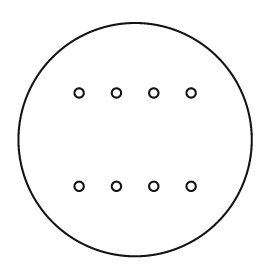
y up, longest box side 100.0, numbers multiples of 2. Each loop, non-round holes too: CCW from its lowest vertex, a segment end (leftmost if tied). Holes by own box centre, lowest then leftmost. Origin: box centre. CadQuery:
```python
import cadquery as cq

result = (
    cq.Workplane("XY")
    .moveTo(0.0, 0.0)
    .circle(50.0)
    .moveTo(-24.0, -20.0)
    .circle(2.0)
    .moveTo(-8.0, -20.0)
    .circle(2.0)
    .moveTo(8.0, -20.0)
    .circle(2.0)
    .moveTo(24.0, -20.0)
    .circle(2.0)
    .moveTo(-24.0, 20.0)
    .circle(2.0)
    .moveTo(-8.0, 20.0)
    .circle(2.0)
    .moveTo(8.0, 20.0)
    .circle(2.0)
    .moveTo(24.0, 20.0)
    .circle(2.0)
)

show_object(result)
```